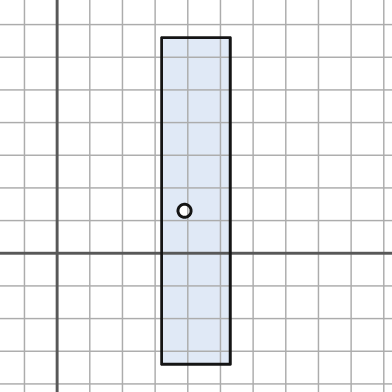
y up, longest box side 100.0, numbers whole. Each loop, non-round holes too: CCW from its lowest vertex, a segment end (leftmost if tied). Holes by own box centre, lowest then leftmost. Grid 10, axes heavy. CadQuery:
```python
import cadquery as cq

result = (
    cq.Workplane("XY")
    .moveTo(32.0, -34.0)
    .lineTo(53.0, -34.0)
    .lineTo(53.0, 66.0)
    .lineTo(32.0, 66.0)
    .close()
    .moveTo(39.0, 13.0)
    .circle(2.0)
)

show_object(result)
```